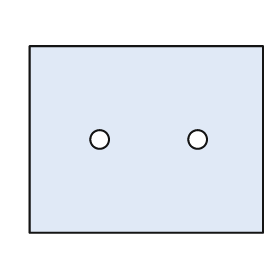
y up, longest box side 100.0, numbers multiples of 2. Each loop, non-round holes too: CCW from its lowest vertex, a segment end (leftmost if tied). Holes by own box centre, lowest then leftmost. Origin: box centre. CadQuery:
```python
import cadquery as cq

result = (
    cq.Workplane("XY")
    .moveTo(-50.0, -40.0)
    .lineTo(50.0, -40.0)
    .lineTo(50.0, 40.0)
    .lineTo(-50.0, 40.0)
    .close()
    .moveTo(-20.0, 0.0)
    .circle(4.0)
    .moveTo(22.0, 0.0)
    .circle(4.0)
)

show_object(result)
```